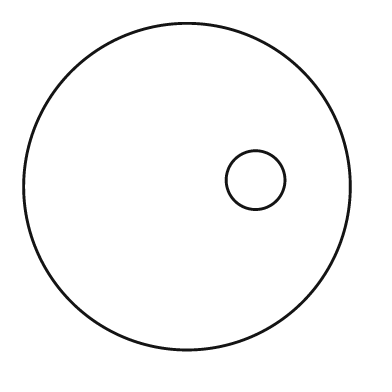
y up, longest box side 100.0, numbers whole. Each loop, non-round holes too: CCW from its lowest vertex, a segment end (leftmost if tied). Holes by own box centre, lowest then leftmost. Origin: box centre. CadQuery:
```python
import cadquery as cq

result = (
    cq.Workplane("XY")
    .moveTo(0.0, 0.0)
    .circle(50.0)
    .moveTo(21.0, 2.0)
    .circle(9.0)
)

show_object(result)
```